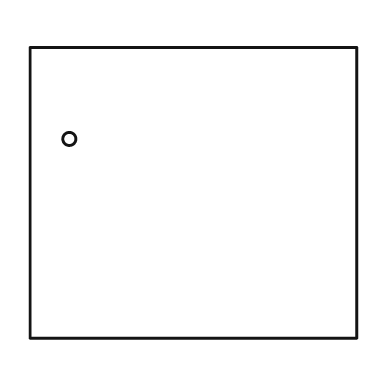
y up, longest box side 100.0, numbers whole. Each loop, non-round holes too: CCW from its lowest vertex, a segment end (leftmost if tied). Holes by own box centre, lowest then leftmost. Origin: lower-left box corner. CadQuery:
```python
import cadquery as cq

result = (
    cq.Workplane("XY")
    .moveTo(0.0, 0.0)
    .lineTo(100.0, 0.0)
    .lineTo(100.0, 89.0)
    .lineTo(0.0, 89.0)
    .close()
    .moveTo(12.0, 61.0)
    .circle(2.0)
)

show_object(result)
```